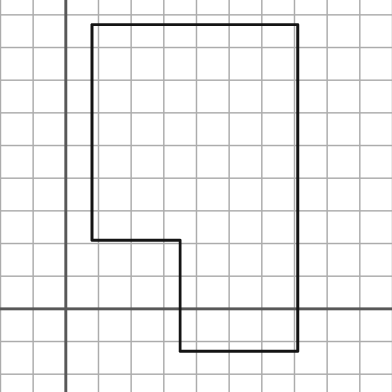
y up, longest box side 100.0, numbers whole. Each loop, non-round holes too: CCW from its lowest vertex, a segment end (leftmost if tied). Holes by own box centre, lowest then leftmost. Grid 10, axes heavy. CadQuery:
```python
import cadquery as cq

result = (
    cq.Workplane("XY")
    .moveTo(35.0, -13.0)
    .lineTo(71.0, -13.0)
    .lineTo(71.0, 87.0)
    .lineTo(8.0, 87.0)
    .lineTo(8.0, 21.0)
    .lineTo(35.0, 21.0)
    .close()
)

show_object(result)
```